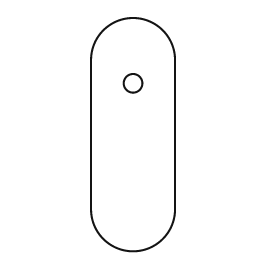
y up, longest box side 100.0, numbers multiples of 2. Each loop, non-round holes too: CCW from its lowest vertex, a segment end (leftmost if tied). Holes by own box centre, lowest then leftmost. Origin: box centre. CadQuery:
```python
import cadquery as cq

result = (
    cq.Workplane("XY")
    .moveTo(-18.0, -32.0)
    .threePointArc((0.0, -50.0), (18.0, -32.0))
    .lineTo(18.0, 32.0)
    .threePointArc((0.0, 50.0), (-18.0, 32.0))
    .close()
    .moveTo(0.0, 22.0)
    .circle(4.0)
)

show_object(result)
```